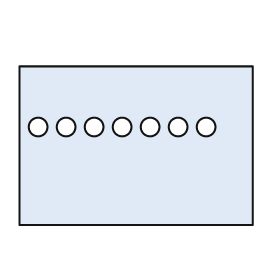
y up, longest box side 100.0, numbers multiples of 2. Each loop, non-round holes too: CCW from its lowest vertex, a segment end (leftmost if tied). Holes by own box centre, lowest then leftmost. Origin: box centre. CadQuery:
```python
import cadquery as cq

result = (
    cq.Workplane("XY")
    .moveTo(-50.0, -34.0)
    .lineTo(50.0, -34.0)
    .lineTo(50.0, 34.0)
    .lineTo(-50.0, 34.0)
    .close()
    .moveTo(-42.0, 8.0)
    .circle(4.0)
    .moveTo(-30.0, 8.0)
    .circle(4.0)
    .moveTo(-18.0, 8.0)
    .circle(4.0)
    .moveTo(-6.0, 8.0)
    .circle(4.0)
    .moveTo(6.0, 8.0)
    .circle(4.0)
    .moveTo(18.0, 8.0)
    .circle(4.0)
    .moveTo(30.0, 8.0)
    .circle(4.0)
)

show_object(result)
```